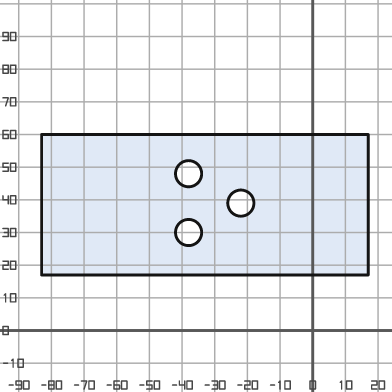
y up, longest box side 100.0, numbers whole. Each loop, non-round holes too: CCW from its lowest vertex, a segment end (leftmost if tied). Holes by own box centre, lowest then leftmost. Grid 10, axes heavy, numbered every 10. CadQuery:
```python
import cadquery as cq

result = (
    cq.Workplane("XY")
    .moveTo(-83.0, 17.0)
    .lineTo(17.0, 17.0)
    .lineTo(17.0, 60.0)
    .lineTo(-83.0, 60.0)
    .close()
    .moveTo(-38.0, 30.0)
    .circle(4.0)
    .moveTo(-22.0, 39.0)
    .circle(4.0)
    .moveTo(-38.0, 48.0)
    .circle(4.0)
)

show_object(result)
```